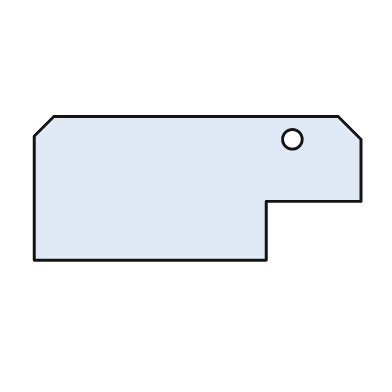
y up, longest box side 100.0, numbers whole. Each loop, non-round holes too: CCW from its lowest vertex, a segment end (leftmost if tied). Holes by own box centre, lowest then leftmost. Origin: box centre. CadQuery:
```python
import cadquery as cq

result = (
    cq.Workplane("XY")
    .moveTo(-50.0, -22.0)
    .lineTo(21.0, -22.0)
    .lineTo(21.0, -4.0)
    .lineTo(50.0, -4.0)
    .lineTo(50.0, 15.0)
    .lineTo(43.0, 22.0)
    .lineTo(-44.0, 22.0)
    .lineTo(-50.0, 16.0)
    .close()
    .moveTo(29.0, 15.0)
    .circle(3.0)
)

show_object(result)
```